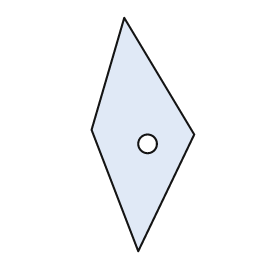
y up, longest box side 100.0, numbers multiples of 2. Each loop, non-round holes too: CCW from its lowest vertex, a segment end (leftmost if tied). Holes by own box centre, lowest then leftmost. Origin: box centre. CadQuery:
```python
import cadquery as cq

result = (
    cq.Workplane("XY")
    .moveTo(-2.0, -50.0)
    .lineTo(22.0, 0.0)
    .lineTo(-8.0, 50.0)
    .lineTo(-22.0, 2.0)
    .close()
    .moveTo(2.0, -4.0)
    .circle(4.0)
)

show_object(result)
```